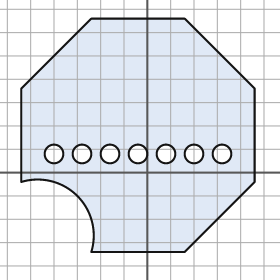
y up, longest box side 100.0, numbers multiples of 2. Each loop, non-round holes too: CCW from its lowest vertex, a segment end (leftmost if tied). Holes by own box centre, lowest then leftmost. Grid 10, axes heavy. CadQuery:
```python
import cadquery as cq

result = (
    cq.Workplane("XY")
    .moveTo(-24.0, -34.0)
    .lineTo(16.0, -34.0)
    .lineTo(46.0, -4.0)
    .lineTo(46.0, 36.0)
    .lineTo(16.0, 66.0)
    .lineTo(-24.0, 66.0)
    .lineTo(-54.0, 36.0)
    .lineTo(-54.0, -4.0)
    .threePointArc((-30.0, -10.0), (-24.0, -34.0))
    .close()
    .moveTo(-40.0, 8.0)
    .circle(4.0)
    .moveTo(-28.0, 8.0)
    .circle(4.0)
    .moveTo(-16.0, 8.0)
    .circle(4.0)
    .moveTo(-4.0, 8.0)
    .circle(4.0)
    .moveTo(8.0, 8.0)
    .circle(4.0)
    .moveTo(20.0, 8.0)
    .circle(4.0)
    .moveTo(32.0, 8.0)
    .circle(4.0)
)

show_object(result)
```